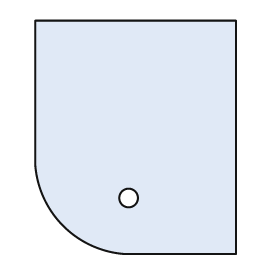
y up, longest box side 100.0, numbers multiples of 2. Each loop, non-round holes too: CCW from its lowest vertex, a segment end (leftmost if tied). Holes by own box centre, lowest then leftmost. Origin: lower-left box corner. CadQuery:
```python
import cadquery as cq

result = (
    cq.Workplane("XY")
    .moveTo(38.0, 0.0)
    .lineTo(86.0, 0.0)
    .lineTo(86.0, 100.0)
    .lineTo(0.0, 100.0)
    .lineTo(0.0, 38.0)
    .threePointArc((12.0, 12.0), (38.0, 0.0))
    .close()
    .moveTo(40.0, 24.0)
    .circle(4.0)
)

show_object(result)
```